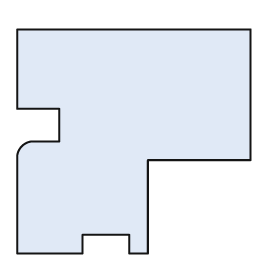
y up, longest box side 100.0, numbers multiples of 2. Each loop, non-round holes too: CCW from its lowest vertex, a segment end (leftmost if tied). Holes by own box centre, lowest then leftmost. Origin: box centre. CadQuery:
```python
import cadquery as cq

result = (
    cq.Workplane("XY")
    .moveTo(-50.0, -48.0)
    .lineTo(-22.0, -48.0)
    .lineTo(-22.0, -40.0)
    .lineTo(-2.0, -40.0)
    .lineTo(-2.0, -48.0)
    .lineTo(6.0, -48.0)
    .lineTo(6.0, -8.0)
    .lineTo(50.0, -8.0)
    .lineTo(50.0, 48.0)
    .lineTo(-50.0, 48.0)
    .lineTo(-50.0, 14.0)
    .lineTo(-32.0, 14.0)
    .lineTo(-32.0, 0.0)
    .lineTo(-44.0, 0.0)
    .threePointArc((-48.0, -2.0), (-50.0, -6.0))
    .close()
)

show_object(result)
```